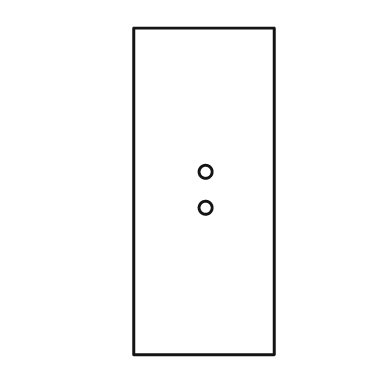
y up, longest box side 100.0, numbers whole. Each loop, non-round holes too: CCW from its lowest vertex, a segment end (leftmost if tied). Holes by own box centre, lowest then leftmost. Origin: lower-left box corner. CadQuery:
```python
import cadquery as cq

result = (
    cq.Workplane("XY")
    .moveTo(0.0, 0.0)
    .lineTo(43.0, 0.0)
    .lineTo(43.0, 100.0)
    .lineTo(0.0, 100.0)
    .close()
    .moveTo(22.0, 45.0)
    .circle(2.0)
    .moveTo(22.0, 56.0)
    .circle(2.0)
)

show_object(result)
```